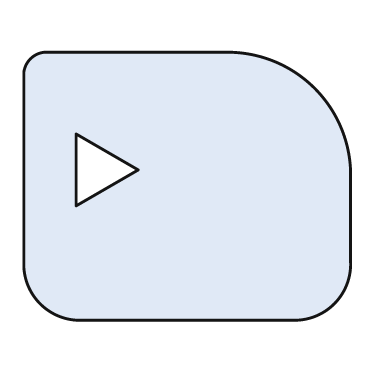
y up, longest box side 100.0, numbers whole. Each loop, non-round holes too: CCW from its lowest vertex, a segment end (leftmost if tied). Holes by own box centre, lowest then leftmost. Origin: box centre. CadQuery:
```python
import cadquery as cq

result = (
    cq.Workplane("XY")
    .moveTo(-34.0, -41.0)
    .lineTo(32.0, -41.0)
    .threePointArc((45.0, -36.0), (50.0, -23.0))
    .lineTo(50.0, 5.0)
    .threePointArc((39.0, 30.0), (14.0, 41.0))
    .lineTo(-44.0, 41.0)
    .threePointArc((-48.0, 39.0), (-50.0, 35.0))
    .lineTo(-50.0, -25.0)
    .threePointArc((-45.0, -36.0), (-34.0, -41.0))
    .close()
    .moveTo(-34.0, -6.0)
    .lineTo(-15.0, 5.0)
    .lineTo(-34.0, 16.0)
    .close()
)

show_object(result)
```